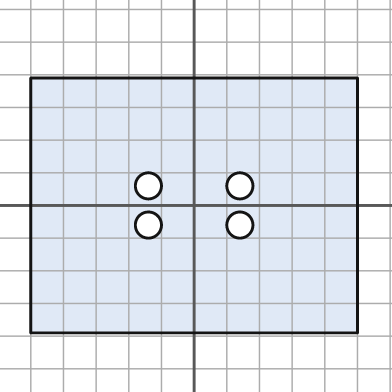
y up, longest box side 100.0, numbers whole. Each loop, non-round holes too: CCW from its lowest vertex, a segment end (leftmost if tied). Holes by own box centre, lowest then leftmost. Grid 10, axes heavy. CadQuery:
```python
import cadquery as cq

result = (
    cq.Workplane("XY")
    .moveTo(-50.0, -39.0)
    .lineTo(50.0, -39.0)
    .lineTo(50.0, 39.0)
    .lineTo(-50.0, 39.0)
    .close()
    .moveTo(-14.0, -6.0)
    .circle(4.0)
    .moveTo(14.0, -6.0)
    .circle(4.0)
    .moveTo(-14.0, 6.0)
    .circle(4.0)
    .moveTo(14.0, 6.0)
    .circle(4.0)
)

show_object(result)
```